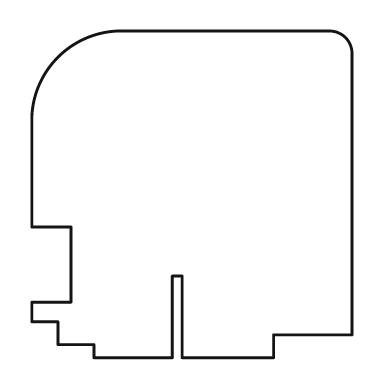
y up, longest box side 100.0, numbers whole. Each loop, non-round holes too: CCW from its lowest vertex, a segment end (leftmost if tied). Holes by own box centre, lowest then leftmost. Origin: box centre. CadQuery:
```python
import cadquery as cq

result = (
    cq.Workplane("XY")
    .moveTo(-30.0, -50.0)
    .lineTo(-6.0, -50.0)
    .lineTo(-6.0, -25.0)
    .lineTo(-3.0, -25.0)
    .lineTo(-3.0, -50.0)
    .lineTo(25.0, -50.0)
    .lineTo(25.0, -43.0)
    .lineTo(49.0, -43.0)
    .lineTo(49.0, 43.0)
    .threePointArc((47.0, 48.0), (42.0, 50.0))
    .lineTo(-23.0, 50.0)
    .threePointArc((-41.0, 42.0), (-49.0, 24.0))
    .lineTo(-49.0, -10.0)
    .lineTo(-37.0, -10.0)
    .lineTo(-37.0, -33.0)
    .lineTo(-49.0, -33.0)
    .lineTo(-49.0, -39.0)
    .lineTo(-41.0, -39.0)
    .lineTo(-41.0, -46.0)
    .lineTo(-30.0, -46.0)
    .close()
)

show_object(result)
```